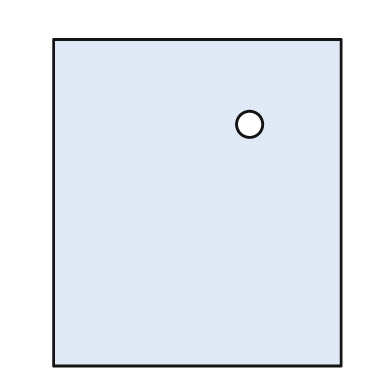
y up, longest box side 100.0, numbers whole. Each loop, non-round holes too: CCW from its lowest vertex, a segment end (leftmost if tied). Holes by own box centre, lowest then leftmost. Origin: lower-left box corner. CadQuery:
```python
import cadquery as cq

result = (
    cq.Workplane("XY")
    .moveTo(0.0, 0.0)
    .lineTo(88.0, 0.0)
    .lineTo(88.0, 100.0)
    .lineTo(0.0, 100.0)
    .close()
    .moveTo(60.0, 74.0)
    .circle(4.0)
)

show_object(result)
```